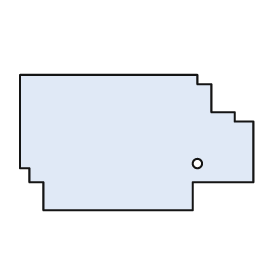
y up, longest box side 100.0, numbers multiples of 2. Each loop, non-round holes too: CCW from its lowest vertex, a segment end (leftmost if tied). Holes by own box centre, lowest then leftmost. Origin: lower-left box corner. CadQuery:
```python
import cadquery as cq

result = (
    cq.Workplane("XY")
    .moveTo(10.0, 0.0)
    .lineTo(74.0, 0.0)
    .lineTo(74.0, 12.0)
    .lineTo(100.0, 12.0)
    .lineTo(100.0, 38.0)
    .lineTo(92.0, 38.0)
    .lineTo(92.0, 42.0)
    .lineTo(82.0, 42.0)
    .lineTo(82.0, 54.0)
    .lineTo(76.0, 54.0)
    .lineTo(76.0, 58.0)
    .lineTo(0.0, 58.0)
    .lineTo(0.0, 18.0)
    .lineTo(4.0, 18.0)
    .lineTo(4.0, 12.0)
    .lineTo(10.0, 12.0)
    .close()
    .moveTo(76.0, 20.0)
    .circle(2.0)
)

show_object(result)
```